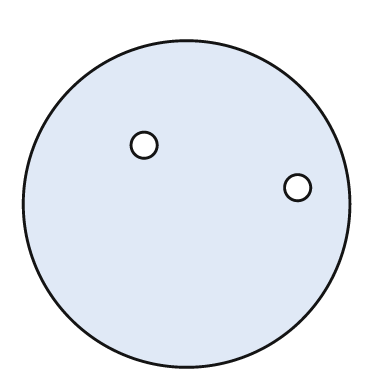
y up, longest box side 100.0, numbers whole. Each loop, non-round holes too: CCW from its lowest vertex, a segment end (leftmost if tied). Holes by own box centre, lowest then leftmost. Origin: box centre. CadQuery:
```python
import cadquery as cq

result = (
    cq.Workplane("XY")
    .moveTo(0.0, 0.0)
    .circle(50.0)
    .moveTo(34.0, 5.0)
    .circle(4.0)
    .moveTo(-13.0, 18.0)
    .circle(4.0)
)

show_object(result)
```